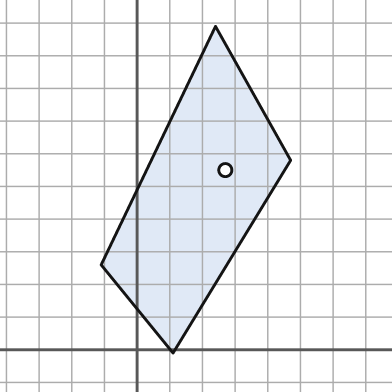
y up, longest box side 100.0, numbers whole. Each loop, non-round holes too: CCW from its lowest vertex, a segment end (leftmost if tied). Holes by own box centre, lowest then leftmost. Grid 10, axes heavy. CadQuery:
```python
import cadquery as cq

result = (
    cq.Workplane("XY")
    .moveTo(11.0, -1.0)
    .lineTo(47.0, 58.0)
    .lineTo(24.0, 99.0)
    .lineTo(-11.0, 26.0)
    .close()
    .moveTo(27.0, 55.0)
    .circle(2.0)
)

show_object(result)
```